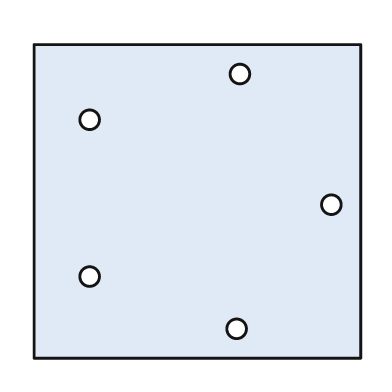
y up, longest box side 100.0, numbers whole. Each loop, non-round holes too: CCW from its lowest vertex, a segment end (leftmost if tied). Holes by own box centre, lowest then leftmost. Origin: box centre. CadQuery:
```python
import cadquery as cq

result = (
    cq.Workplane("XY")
    .moveTo(-50.0, -48.0)
    .lineTo(50.0, -48.0)
    .lineTo(50.0, 48.0)
    .lineTo(-50.0, 48.0)
    .close()
    .moveTo(12.0, -39.0)
    .circle(3.0)
    .moveTo(-33.0, -23.0)
    .circle(3.0)
    .moveTo(41.0, -1.0)
    .circle(3.0)
    .moveTo(-33.0, 25.0)
    .circle(3.0)
    .moveTo(13.0, 39.0)
    .circle(3.0)
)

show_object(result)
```